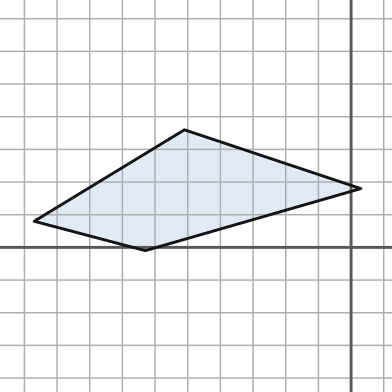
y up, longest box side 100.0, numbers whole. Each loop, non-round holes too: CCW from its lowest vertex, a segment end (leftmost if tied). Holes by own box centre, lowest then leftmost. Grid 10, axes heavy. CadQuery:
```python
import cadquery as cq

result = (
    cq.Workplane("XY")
    .moveTo(-63.0, -1.0)
    .lineTo(3.0, 18.0)
    .lineTo(-51.0, 36.0)
    .lineTo(-97.0, 8.0)
    .close()
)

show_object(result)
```